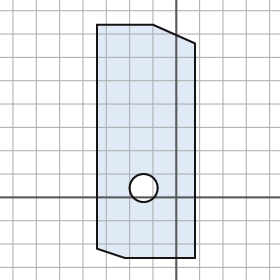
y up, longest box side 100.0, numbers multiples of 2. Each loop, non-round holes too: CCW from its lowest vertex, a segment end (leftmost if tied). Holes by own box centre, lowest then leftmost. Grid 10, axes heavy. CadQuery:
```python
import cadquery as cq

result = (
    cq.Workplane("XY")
    .moveTo(-22.0, -26.0)
    .lineTo(8.0, -26.0)
    .lineTo(8.0, 66.0)
    .lineTo(-10.0, 74.0)
    .lineTo(-34.0, 74.0)
    .lineTo(-34.0, -22.0)
    .close()
    .moveTo(-14.0, 4.0)
    .circle(6.0)
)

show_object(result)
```